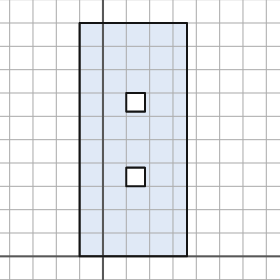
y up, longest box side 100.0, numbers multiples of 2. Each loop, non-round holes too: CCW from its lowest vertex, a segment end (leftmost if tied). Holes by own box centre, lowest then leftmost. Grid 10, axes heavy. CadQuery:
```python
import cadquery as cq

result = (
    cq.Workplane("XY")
    .moveTo(-10.0, 0.0)
    .lineTo(36.0, 0.0)
    .lineTo(36.0, 100.0)
    .lineTo(-10.0, 100.0)
    .close()
    .moveTo(10.0, 30.0)
    .lineTo(18.0, 30.0)
    .lineTo(18.0, 38.0)
    .lineTo(10.0, 38.0)
    .close()
    .moveTo(10.0, 62.0)
    .lineTo(18.0, 62.0)
    .lineTo(18.0, 70.0)
    .lineTo(10.0, 70.0)
    .close()
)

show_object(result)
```